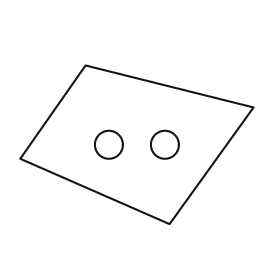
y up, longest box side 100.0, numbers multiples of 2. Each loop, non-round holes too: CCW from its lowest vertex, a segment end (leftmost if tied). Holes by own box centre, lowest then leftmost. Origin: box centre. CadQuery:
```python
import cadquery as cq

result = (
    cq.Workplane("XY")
    .moveTo(14.0, -34.0)
    .lineTo(50.0, 16.0)
    .lineTo(-22.0, 34.0)
    .lineTo(-50.0, -6.0)
    .close()
    .moveTo(-12.0, 0.0)
    .circle(6.0)
    .moveTo(12.0, 0.0)
    .circle(6.0)
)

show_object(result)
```